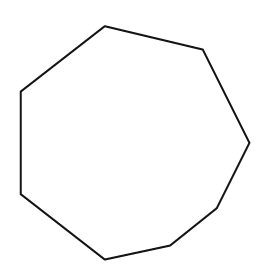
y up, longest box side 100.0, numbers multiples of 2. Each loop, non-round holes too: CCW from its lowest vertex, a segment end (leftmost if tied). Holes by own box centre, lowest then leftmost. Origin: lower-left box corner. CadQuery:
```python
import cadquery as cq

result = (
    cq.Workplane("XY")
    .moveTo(36.0, 0.0)
    .lineTo(64.0, 6.0)
    .lineTo(84.0, 22.0)
    .lineTo(98.0, 50.0)
    .lineTo(78.0, 90.0)
    .lineTo(36.0, 100.0)
    .lineTo(0.0, 72.0)
    .lineTo(0.0, 28.0)
    .close()
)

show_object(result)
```